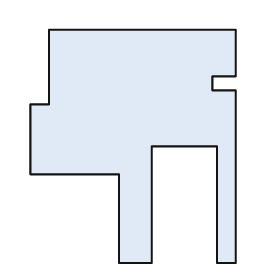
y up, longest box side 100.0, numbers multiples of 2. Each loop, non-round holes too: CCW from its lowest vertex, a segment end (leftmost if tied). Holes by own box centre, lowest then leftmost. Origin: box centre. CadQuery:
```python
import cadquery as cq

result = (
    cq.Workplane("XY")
    .moveTo(-6.0, -50.0)
    .lineTo(8.0, -50.0)
    .lineTo(8.0, 0.0)
    .lineTo(36.0, 0.0)
    .lineTo(36.0, -50.0)
    .lineTo(44.0, -50.0)
    .lineTo(44.0, 24.0)
    .lineTo(34.0, 24.0)
    .lineTo(34.0, 30.0)
    .lineTo(44.0, 30.0)
    .lineTo(44.0, 50.0)
    .lineTo(-36.0, 50.0)
    .lineTo(-36.0, 18.0)
    .lineTo(-44.0, 18.0)
    .lineTo(-44.0, -12.0)
    .lineTo(-6.0, -12.0)
    .close()
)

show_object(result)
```